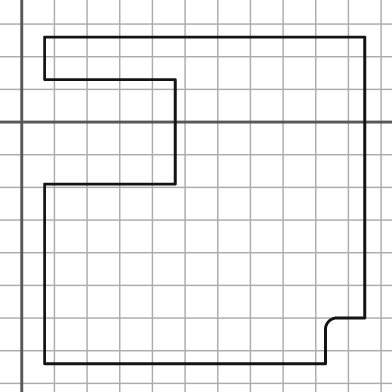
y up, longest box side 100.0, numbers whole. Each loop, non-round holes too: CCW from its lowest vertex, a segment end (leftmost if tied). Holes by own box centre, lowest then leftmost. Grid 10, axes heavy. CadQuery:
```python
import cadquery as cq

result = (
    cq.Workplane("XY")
    .moveTo(7.0, -74.0)
    .lineTo(93.0, -74.0)
    .lineTo(93.0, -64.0)
    .threePointArc((94.0, -61.0), (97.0, -60.0))
    .lineTo(105.0, -60.0)
    .lineTo(105.0, 26.0)
    .lineTo(7.0, 26.0)
    .lineTo(7.0, 13.0)
    .lineTo(47.0, 13.0)
    .lineTo(47.0, -19.0)
    .lineTo(7.0, -19.0)
    .close()
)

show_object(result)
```